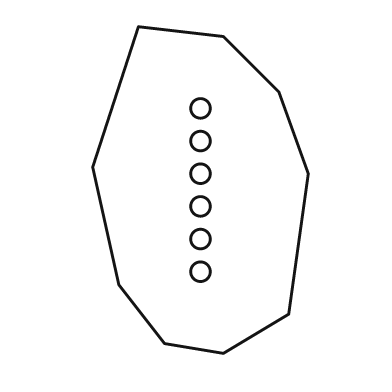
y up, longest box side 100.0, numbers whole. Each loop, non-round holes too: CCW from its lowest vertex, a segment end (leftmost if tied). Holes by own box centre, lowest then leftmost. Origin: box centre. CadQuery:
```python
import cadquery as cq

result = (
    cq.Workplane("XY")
    .moveTo(7.0, -50.0)
    .lineTo(27.0, -38.0)
    .lineTo(33.0, 5.0)
    .lineTo(24.0, 30.0)
    .lineTo(7.0, 47.0)
    .lineTo(-19.0, 50.0)
    .lineTo(-33.0, 7.0)
    .lineTo(-25.0, -29.0)
    .lineTo(-11.0, -47.0)
    .close()
    .moveTo(0.0, -25.0)
    .circle(3.0)
    .moveTo(0.0, -15.0)
    .circle(3.0)
    .moveTo(0.0, -5.0)
    .circle(3.0)
    .moveTo(0.0, 5.0)
    .circle(3.0)
    .moveTo(0.0, 15.0)
    .circle(3.0)
    .moveTo(0.0, 25.0)
    .circle(3.0)
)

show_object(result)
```